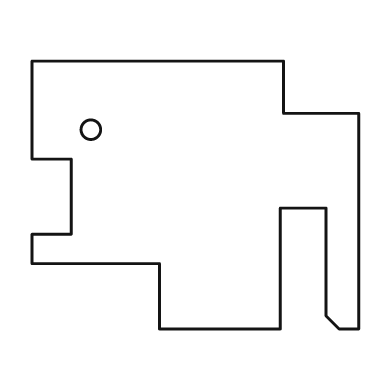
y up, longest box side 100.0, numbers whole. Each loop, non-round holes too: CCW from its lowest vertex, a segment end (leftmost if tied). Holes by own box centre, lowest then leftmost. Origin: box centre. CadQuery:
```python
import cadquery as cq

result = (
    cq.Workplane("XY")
    .moveTo(-11.0, -41.0)
    .lineTo(26.0, -41.0)
    .lineTo(26.0, -4.0)
    .lineTo(40.0, -4.0)
    .lineTo(40.0, -37.0)
    .lineTo(44.0, -41.0)
    .lineTo(50.0, -41.0)
    .lineTo(50.0, 25.0)
    .lineTo(27.0, 25.0)
    .lineTo(27.0, 41.0)
    .lineTo(-50.0, 41.0)
    .lineTo(-50.0, 11.0)
    .lineTo(-38.0, 11.0)
    .lineTo(-38.0, -12.0)
    .lineTo(-50.0, -12.0)
    .lineTo(-50.0, -21.0)
    .lineTo(-11.0, -21.0)
    .close()
    .moveTo(-32.0, 20.0)
    .circle(3.0)
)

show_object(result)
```